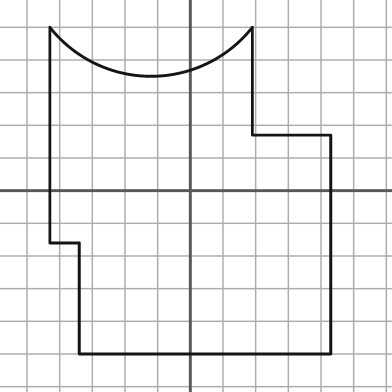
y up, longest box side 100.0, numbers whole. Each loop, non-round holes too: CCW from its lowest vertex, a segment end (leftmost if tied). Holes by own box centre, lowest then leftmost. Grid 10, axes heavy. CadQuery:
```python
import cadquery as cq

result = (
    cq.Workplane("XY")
    .moveTo(-34.0, -50.0)
    .lineTo(43.0, -50.0)
    .lineTo(43.0, 17.0)
    .lineTo(19.0, 17.0)
    .lineTo(19.0, 50.0)
    .threePointArc((-12.0, 35.0), (-43.0, 50.0))
    .lineTo(-43.0, -16.0)
    .lineTo(-34.0, -16.0)
    .close()
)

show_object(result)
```